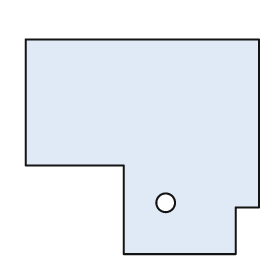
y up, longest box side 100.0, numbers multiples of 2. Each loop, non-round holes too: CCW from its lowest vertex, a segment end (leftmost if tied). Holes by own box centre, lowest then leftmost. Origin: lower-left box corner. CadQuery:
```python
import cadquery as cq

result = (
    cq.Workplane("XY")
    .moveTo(42.0, 0.0)
    .lineTo(90.0, 0.0)
    .lineTo(90.0, 20.0)
    .lineTo(100.0, 20.0)
    .lineTo(100.0, 92.0)
    .lineTo(0.0, 92.0)
    .lineTo(0.0, 38.0)
    .lineTo(42.0, 38.0)
    .close()
    .moveTo(60.0, 22.0)
    .circle(4.0)
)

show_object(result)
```